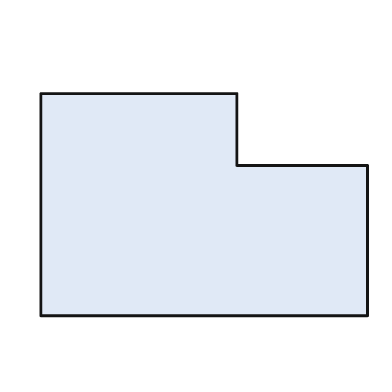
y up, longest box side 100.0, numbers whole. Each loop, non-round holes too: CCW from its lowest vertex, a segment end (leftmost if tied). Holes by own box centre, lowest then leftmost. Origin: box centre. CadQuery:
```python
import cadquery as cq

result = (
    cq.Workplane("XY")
    .moveTo(-50.0, -34.0)
    .lineTo(50.0, -34.0)
    .lineTo(50.0, 12.0)
    .lineTo(10.0, 12.0)
    .lineTo(10.0, 34.0)
    .lineTo(-50.0, 34.0)
    .close()
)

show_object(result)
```